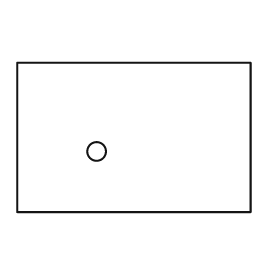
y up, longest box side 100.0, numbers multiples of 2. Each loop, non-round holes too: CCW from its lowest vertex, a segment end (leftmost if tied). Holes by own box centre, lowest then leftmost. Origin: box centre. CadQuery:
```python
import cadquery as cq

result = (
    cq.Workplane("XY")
    .moveTo(-50.0, -32.0)
    .lineTo(50.0, -32.0)
    .lineTo(50.0, 32.0)
    .lineTo(-50.0, 32.0)
    .close()
    .moveTo(-16.0, -6.0)
    .circle(4.0)
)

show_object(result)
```